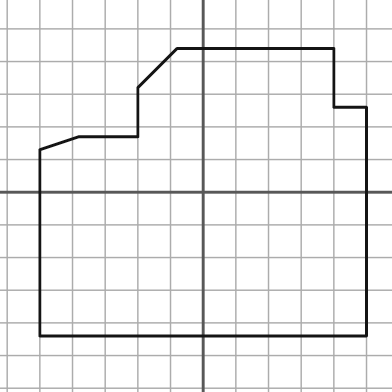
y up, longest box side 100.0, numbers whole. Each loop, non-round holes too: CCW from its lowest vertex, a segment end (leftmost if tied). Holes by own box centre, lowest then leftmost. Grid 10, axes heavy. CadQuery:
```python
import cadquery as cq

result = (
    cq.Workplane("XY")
    .moveTo(-50.0, -44.0)
    .lineTo(50.0, -44.0)
    .lineTo(50.0, 26.0)
    .lineTo(40.0, 26.0)
    .lineTo(40.0, 44.0)
    .lineTo(-8.0, 44.0)
    .lineTo(-20.0, 32.0)
    .lineTo(-20.0, 17.0)
    .lineTo(-38.0, 17.0)
    .lineTo(-50.0, 13.0)
    .close()
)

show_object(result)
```